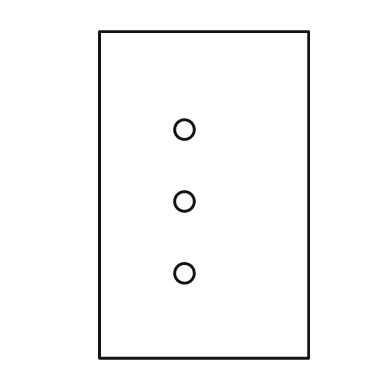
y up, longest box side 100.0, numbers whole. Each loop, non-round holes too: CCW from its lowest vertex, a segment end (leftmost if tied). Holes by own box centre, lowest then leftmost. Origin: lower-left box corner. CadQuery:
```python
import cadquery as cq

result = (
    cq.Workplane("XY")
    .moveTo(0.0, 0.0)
    .lineTo(64.0, 0.0)
    .lineTo(64.0, 100.0)
    .lineTo(0.0, 100.0)
    .close()
    .moveTo(26.0, 26.0)
    .circle(3.0)
    .moveTo(26.0, 48.0)
    .circle(3.0)
    .moveTo(26.0, 70.0)
    .circle(3.0)
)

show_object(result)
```